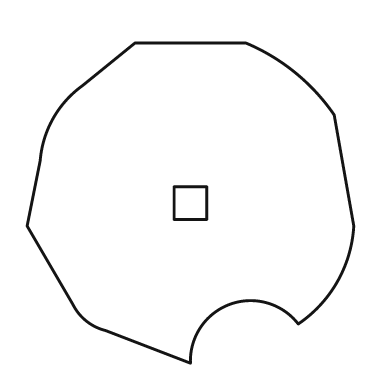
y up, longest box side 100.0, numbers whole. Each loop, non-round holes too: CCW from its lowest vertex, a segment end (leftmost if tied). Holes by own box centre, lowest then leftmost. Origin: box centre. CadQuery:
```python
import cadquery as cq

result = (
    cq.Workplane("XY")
    .moveTo(0.0, -49.0)
    .threePointArc((12.0, -31.0), (33.0, -37.0))
    .threePointArc((45.0, -24.0), (50.0, -7.0))
    .lineTo(44.0, 27.0)
    .threePointArc((32.0, 40.0), (17.0, 49.0))
    .lineTo(-17.0, 49.0)
    .lineTo(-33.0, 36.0)
    .threePointArc((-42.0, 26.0), (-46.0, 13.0))
    .lineTo(-50.0, -7.0)
    .lineTo(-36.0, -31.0)
    .threePointArc((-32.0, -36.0), (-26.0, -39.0))
    .close()
    .moveTo(-5.0, -5.0)
    .lineTo(5.0, -5.0)
    .lineTo(5.0, 5.0)
    .lineTo(-5.0, 5.0)
    .close()
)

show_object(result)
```